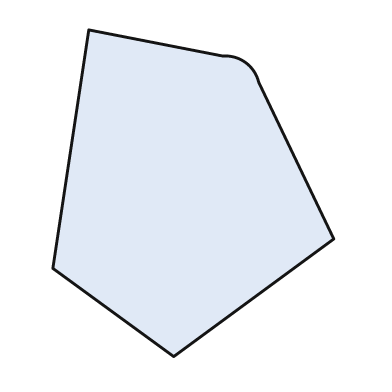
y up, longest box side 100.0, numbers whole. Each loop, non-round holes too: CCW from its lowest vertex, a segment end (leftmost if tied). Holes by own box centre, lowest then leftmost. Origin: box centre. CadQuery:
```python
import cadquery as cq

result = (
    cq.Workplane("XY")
    .moveTo(-6.0, -50.0)
    .lineTo(43.0, -14.0)
    .lineTo(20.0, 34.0)
    .threePointArc((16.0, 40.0), (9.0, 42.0))
    .lineTo(-32.0, 50.0)
    .lineTo(-43.0, -23.0)
    .close()
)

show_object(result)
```